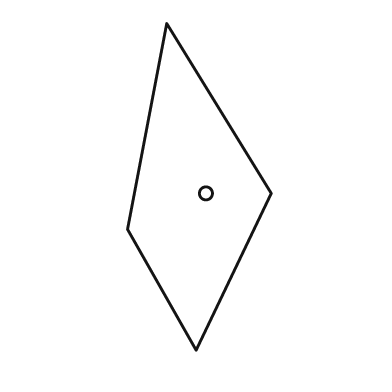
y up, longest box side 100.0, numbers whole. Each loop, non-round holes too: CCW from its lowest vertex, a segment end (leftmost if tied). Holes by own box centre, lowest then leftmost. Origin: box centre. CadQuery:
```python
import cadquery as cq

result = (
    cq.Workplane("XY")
    .moveTo(-1.0, -50.0)
    .lineTo(22.0, -2.0)
    .lineTo(-10.0, 50.0)
    .lineTo(-22.0, -13.0)
    .close()
    .moveTo(2.0, -2.0)
    .circle(2.0)
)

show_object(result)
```